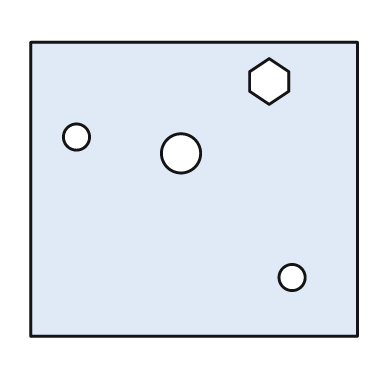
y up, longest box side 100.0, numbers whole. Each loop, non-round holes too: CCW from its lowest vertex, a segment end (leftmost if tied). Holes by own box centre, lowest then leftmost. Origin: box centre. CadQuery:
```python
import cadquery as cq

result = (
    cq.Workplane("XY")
    .moveTo(-50.0, -45.0)
    .lineTo(50.0, -45.0)
    .lineTo(50.0, 45.0)
    .lineTo(-50.0, 45.0)
    .close()
    .moveTo(30.0, -27.0)
    .circle(4.0)
    .moveTo(-4.0, 11.0)
    .circle(6.0)
    .moveTo(-36.0, 16.0)
    .circle(4.0)
    .moveTo(23.0, 26.0)
    .lineTo(29.0, 30.0)
    .lineTo(29.0, 36.0)
    .lineTo(23.0, 40.0)
    .lineTo(17.0, 36.0)
    .lineTo(17.0, 30.0)
    .close()
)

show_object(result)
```